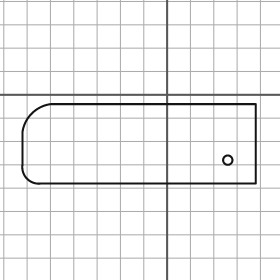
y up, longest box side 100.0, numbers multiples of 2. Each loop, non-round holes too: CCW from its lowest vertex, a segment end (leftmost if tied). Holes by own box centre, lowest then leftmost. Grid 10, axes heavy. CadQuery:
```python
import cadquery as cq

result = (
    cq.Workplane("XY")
    .moveTo(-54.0, -38.0)
    .lineTo(38.0, -38.0)
    .lineTo(38.0, -4.0)
    .lineTo(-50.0, -4.0)
    .threePointArc((-58.0, -8.0), (-62.0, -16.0))
    .lineTo(-62.0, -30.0)
    .threePointArc((-60.0, -36.0), (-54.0, -38.0))
    .close()
    .moveTo(26.0, -28.0)
    .circle(2.0)
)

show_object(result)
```